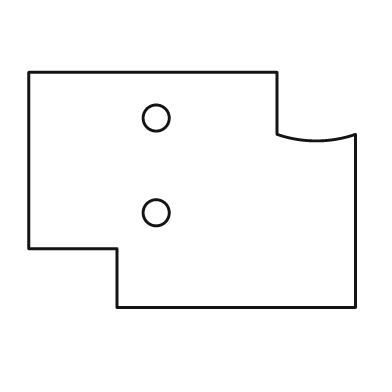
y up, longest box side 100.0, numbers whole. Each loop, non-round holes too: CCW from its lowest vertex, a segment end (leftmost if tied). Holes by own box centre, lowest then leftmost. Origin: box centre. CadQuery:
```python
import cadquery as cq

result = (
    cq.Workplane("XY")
    .moveTo(-23.0, -36.0)
    .lineTo(50.0, -36.0)
    .lineTo(50.0, 17.0)
    .threePointArc((38.0, 15.0), (26.0, 17.0))
    .lineTo(26.0, 36.0)
    .lineTo(-50.0, 36.0)
    .lineTo(-50.0, -18.0)
    .lineTo(-23.0, -18.0)
    .close()
    .moveTo(-11.0, -7.0)
    .circle(4.0)
    .moveTo(-11.0, 22.0)
    .circle(4.0)
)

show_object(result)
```